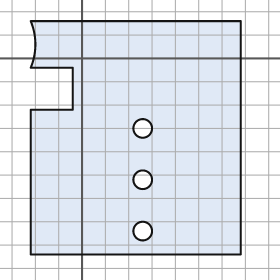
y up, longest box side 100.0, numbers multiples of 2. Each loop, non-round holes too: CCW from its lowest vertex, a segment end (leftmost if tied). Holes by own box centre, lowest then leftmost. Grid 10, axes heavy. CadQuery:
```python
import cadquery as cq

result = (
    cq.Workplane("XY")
    .moveTo(-22.0, -84.0)
    .lineTo(68.0, -84.0)
    .lineTo(68.0, 16.0)
    .lineTo(-22.0, 16.0)
    .threePointArc((-20.0, 6.0), (-22.0, -4.0))
    .lineTo(-4.0, -4.0)
    .lineTo(-4.0, -22.0)
    .lineTo(-22.0, -22.0)
    .close()
    .moveTo(26.0, -74.0)
    .circle(4.0)
    .moveTo(26.0, -52.0)
    .circle(4.0)
    .moveTo(26.0, -30.0)
    .circle(4.0)
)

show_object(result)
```